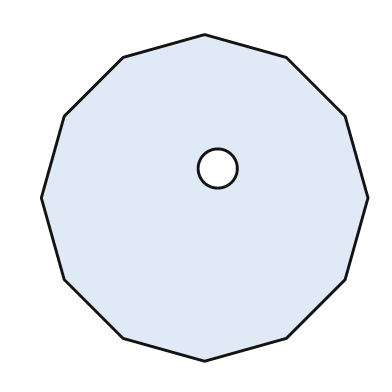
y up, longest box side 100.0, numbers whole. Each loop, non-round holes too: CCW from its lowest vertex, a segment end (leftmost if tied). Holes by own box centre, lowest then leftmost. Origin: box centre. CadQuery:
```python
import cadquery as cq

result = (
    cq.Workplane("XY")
    .moveTo(0.0, -50.0)
    .lineTo(25.0, -43.0)
    .lineTo(43.0, -25.0)
    .lineTo(50.0, 0.0)
    .lineTo(43.0, 25.0)
    .lineTo(25.0, 43.0)
    .lineTo(0.0, 50.0)
    .lineTo(-25.0, 43.0)
    .lineTo(-43.0, 25.0)
    .lineTo(-50.0, 0.0)
    .lineTo(-43.0, -25.0)
    .lineTo(-25.0, -43.0)
    .close()
    .moveTo(4.0, 9.0)
    .circle(6.0)
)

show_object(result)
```